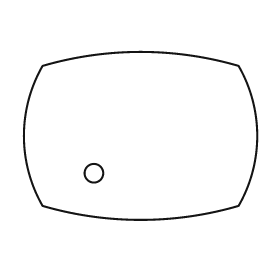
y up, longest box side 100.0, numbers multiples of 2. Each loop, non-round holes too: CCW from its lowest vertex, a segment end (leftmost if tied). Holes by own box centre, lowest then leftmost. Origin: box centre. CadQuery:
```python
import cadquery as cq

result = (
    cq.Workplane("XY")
    .moveTo(-42.0, -30.0)
    .threePointArc((0.0, -36.0), (42.0, -30.0))
    .threePointArc((50.0, 0.0), (42.0, 30.0))
    .threePointArc((0.0, 36.0), (-42.0, 30.0))
    .threePointArc((-50.0, 0.0), (-42.0, -30.0))
    .close()
    .moveTo(-20.0, -16.0)
    .circle(4.0)
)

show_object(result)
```